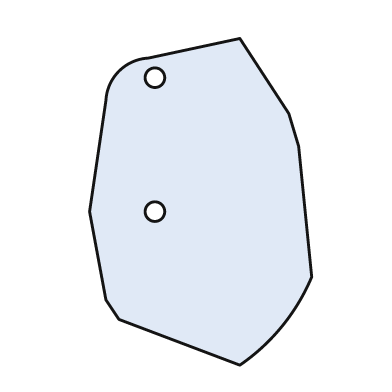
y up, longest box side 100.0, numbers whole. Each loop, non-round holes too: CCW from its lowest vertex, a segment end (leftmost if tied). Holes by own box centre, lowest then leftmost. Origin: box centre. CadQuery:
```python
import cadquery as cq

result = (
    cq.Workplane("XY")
    .moveTo(12.0, -50.0)
    .threePointArc((25.0, -38.0), (34.0, -23.0))
    .lineTo(30.0, 17.0)
    .lineTo(27.0, 27.0)
    .lineTo(12.0, 50.0)
    .lineTo(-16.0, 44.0)
    .threePointArc((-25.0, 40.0), (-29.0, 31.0))
    .lineTo(-34.0, -3.0)
    .lineTo(-29.0, -30.0)
    .lineTo(-25.0, -36.0)
    .close()
    .moveTo(-14.0, -3.0)
    .circle(3.0)
    .moveTo(-14.0, 38.0)
    .circle(3.0)
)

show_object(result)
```